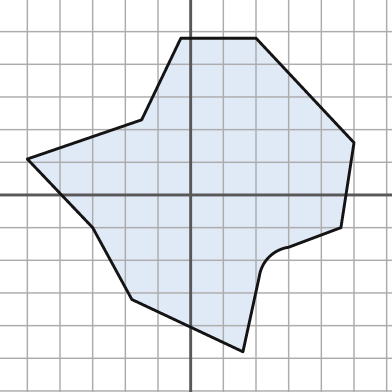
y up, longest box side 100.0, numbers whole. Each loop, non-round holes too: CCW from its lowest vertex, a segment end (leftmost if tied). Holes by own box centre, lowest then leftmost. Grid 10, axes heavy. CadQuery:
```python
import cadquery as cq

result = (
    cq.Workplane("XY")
    .moveTo(16.0, -48.0)
    .lineTo(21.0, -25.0)
    .threePointArc((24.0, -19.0), (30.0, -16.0))
    .lineTo(46.0, -10.0)
    .lineTo(50.0, 16.0)
    .lineTo(20.0, 48.0)
    .lineTo(-3.0, 48.0)
    .lineTo(-15.0, 23.0)
    .lineTo(-50.0, 11.0)
    .lineTo(-30.0, -10.0)
    .lineTo(-18.0, -32.0)
    .close()
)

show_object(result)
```